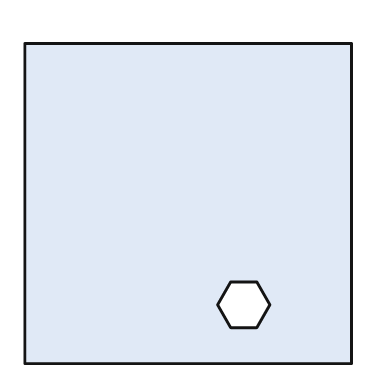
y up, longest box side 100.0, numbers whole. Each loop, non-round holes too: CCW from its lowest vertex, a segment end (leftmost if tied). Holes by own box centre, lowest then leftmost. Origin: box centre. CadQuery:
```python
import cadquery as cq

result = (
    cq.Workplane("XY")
    .moveTo(-50.0, -49.0)
    .lineTo(50.0, -49.0)
    .lineTo(50.0, 49.0)
    .lineTo(-50.0, 49.0)
    .close()
    .moveTo(13.0, -38.0)
    .lineTo(21.0, -38.0)
    .lineTo(25.0, -31.0)
    .lineTo(21.0, -24.0)
    .lineTo(13.0, -24.0)
    .lineTo(9.0, -31.0)
    .close()
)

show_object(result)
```